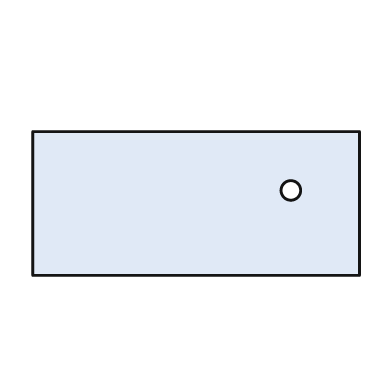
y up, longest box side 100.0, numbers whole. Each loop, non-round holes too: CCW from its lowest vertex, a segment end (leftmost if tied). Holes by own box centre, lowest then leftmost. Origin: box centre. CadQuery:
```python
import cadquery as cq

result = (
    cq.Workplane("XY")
    .moveTo(-50.0, -22.0)
    .lineTo(50.0, -22.0)
    .lineTo(50.0, 22.0)
    .lineTo(-50.0, 22.0)
    .close()
    .moveTo(29.0, 4.0)
    .circle(3.0)
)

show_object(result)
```